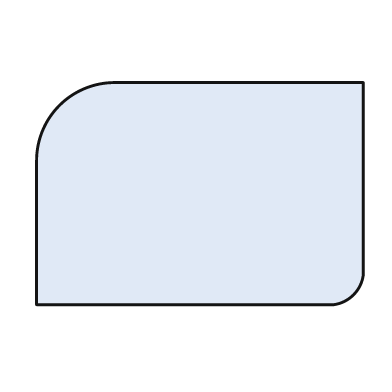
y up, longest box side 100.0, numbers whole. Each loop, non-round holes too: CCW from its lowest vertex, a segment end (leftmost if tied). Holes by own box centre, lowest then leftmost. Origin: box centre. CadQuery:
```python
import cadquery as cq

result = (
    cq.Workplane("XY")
    .moveTo(-50.0, -34.0)
    .lineTo(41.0, -34.0)
    .threePointArc((47.0, -31.0), (50.0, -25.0))
    .lineTo(50.0, 34.0)
    .lineTo(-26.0, 34.0)
    .threePointArc((-43.0, 27.0), (-50.0, 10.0))
    .close()
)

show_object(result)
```